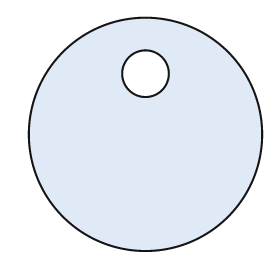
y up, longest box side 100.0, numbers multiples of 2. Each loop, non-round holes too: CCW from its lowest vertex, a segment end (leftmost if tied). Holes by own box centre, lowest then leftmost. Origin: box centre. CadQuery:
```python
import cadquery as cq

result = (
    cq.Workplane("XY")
    .moveTo(0.0, 0.0)
    .circle(50.0)
    .moveTo(0.0, 26.0)
    .circle(10.0)
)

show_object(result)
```